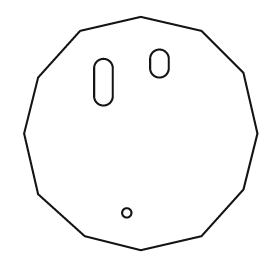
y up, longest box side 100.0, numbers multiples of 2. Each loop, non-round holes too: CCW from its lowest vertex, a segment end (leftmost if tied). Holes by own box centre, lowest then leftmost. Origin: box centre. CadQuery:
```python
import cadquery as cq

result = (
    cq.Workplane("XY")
    .moveTo(0.0, -50.0)
    .lineTo(26.0, -44.0)
    .lineTo(44.0, -24.0)
    .lineTo(50.0, 0.0)
    .lineTo(44.0, 26.0)
    .lineTo(26.0, 44.0)
    .lineTo(0.0, 50.0)
    .lineTo(-26.0, 44.0)
    .lineTo(-44.0, 24.0)
    .lineTo(-50.0, 0.0)
    .lineTo(-44.0, -26.0)
    .lineTo(-24.0, -44.0)
    .close()
    .moveTo(-6.0, -34.0)
    .circle(2.0)
    .moveTo(-20.0, 16.0)
    .threePointArc((-16.0, 12.0), (-12.0, 16.0))
    .lineTo(-12.0, 28.0)
    .threePointArc((-16.0, 32.0), (-20.0, 28.0))
    .close()
    .moveTo(4.0, 28.0)
    .threePointArc((8.0, 24.0), (12.0, 28.0))
    .lineTo(12.0, 32.0)
    .threePointArc((8.0, 36.0), (4.0, 32.0))
    .close()
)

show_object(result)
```